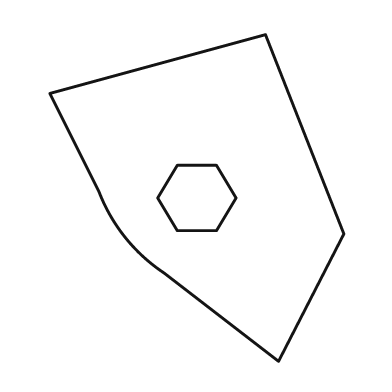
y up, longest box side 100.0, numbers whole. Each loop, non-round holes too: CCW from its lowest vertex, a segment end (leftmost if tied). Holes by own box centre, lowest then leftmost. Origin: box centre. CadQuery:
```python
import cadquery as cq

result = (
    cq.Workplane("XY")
    .moveTo(25.0, -50.0)
    .lineTo(45.0, -11.0)
    .lineTo(21.0, 50.0)
    .lineTo(-45.0, 32.0)
    .lineTo(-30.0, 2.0)
    .threePointArc((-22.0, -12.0), (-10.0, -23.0))
    .close()
    .moveTo(-6.0, -10.0)
    .lineTo(6.0, -10.0)
    .lineTo(12.0, 0.0)
    .lineTo(6.0, 10.0)
    .lineTo(-6.0, 10.0)
    .lineTo(-12.0, 0.0)
    .close()
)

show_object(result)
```